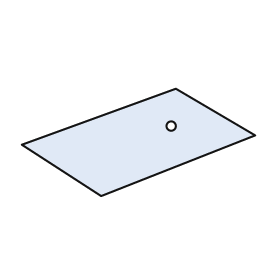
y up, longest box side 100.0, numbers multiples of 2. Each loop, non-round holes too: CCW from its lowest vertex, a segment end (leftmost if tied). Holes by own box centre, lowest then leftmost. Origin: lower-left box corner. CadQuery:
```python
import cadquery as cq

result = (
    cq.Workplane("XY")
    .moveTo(34.0, 0.0)
    .lineTo(100.0, 26.0)
    .lineTo(66.0, 46.0)
    .lineTo(0.0, 22.0)
    .close()
    .moveTo(64.0, 30.0)
    .circle(2.0)
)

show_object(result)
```